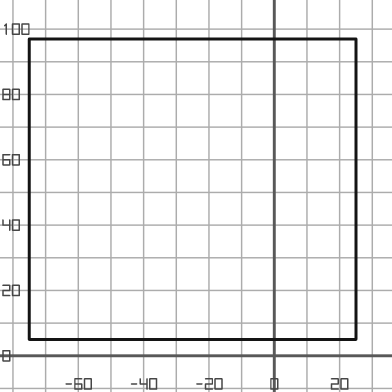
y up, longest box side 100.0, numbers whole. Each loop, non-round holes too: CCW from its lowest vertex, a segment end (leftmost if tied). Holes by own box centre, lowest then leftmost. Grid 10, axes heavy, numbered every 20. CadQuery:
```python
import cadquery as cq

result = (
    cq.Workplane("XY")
    .moveTo(-75.0, 5.0)
    .lineTo(25.0, 5.0)
    .lineTo(25.0, 97.0)
    .lineTo(-75.0, 97.0)
    .close()
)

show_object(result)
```